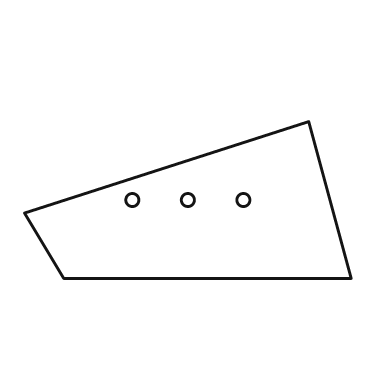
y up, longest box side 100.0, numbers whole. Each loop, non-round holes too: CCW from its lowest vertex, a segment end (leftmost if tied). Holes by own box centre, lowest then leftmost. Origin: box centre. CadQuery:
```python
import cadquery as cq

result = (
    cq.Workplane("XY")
    .moveTo(-38.0, -24.0)
    .lineTo(50.0, -24.0)
    .lineTo(37.0, 24.0)
    .lineTo(-50.0, -4.0)
    .close()
    .moveTo(-17.0, 0.0)
    .circle(2.0)
    .moveTo(0.0, 0.0)
    .circle(2.0)
    .moveTo(17.0, 0.0)
    .circle(2.0)
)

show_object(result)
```